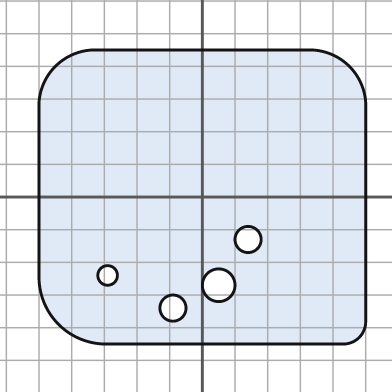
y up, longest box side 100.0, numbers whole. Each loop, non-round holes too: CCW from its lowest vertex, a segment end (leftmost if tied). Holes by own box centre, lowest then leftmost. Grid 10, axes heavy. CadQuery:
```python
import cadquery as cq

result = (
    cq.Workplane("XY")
    .moveTo(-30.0, -45.0)
    .lineTo(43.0, -45.0)
    .threePointArc((48.0, -43.0), (50.0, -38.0))
    .lineTo(50.0, 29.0)
    .threePointArc((45.0, 40.0), (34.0, 45.0))
    .lineTo(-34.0, 45.0)
    .threePointArc((-45.0, 40.0), (-50.0, 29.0))
    .lineTo(-50.0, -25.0)
    .threePointArc((-44.0, -39.0), (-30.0, -45.0))
    .close()
    .moveTo(-9.0, -34.0)
    .circle(4.0)
    .moveTo(5.0, -27.0)
    .circle(5.0)
    .moveTo(-29.0, -24.0)
    .circle(3.0)
    .moveTo(14.0, -13.0)
    .circle(4.0)
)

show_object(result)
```